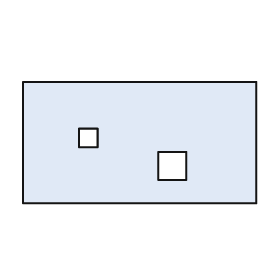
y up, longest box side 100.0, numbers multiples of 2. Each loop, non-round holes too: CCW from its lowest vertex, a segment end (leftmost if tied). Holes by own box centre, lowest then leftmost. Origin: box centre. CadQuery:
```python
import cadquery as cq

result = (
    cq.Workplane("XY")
    .moveTo(-50.0, -26.0)
    .lineTo(50.0, -26.0)
    .lineTo(50.0, 26.0)
    .lineTo(-50.0, 26.0)
    .close()
    .moveTo(8.0, -16.0)
    .lineTo(20.0, -16.0)
    .lineTo(20.0, -4.0)
    .lineTo(8.0, -4.0)
    .close()
    .moveTo(-26.0, -2.0)
    .lineTo(-18.0, -2.0)
    .lineTo(-18.0, 6.0)
    .lineTo(-26.0, 6.0)
    .close()
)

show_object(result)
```